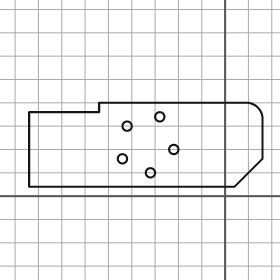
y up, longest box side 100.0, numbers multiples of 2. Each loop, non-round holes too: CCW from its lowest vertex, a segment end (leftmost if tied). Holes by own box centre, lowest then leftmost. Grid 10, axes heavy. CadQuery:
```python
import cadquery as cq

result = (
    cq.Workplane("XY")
    .moveTo(-84.0, 4.0)
    .lineTo(4.0, 4.0)
    .lineTo(16.0, 16.0)
    .lineTo(16.0, 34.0)
    .threePointArc((14.0, 38.0), (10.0, 40.0))
    .lineTo(-54.0, 40.0)
    .lineTo(-54.0, 36.0)
    .lineTo(-84.0, 36.0)
    .close()
    .moveTo(-32.0, 10.0)
    .circle(2.0)
    .moveTo(-44.0, 16.0)
    .circle(2.0)
    .moveTo(-22.0, 20.0)
    .circle(2.0)
    .moveTo(-42.0, 30.0)
    .circle(2.0)
    .moveTo(-28.0, 34.0)
    .circle(2.0)
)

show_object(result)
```